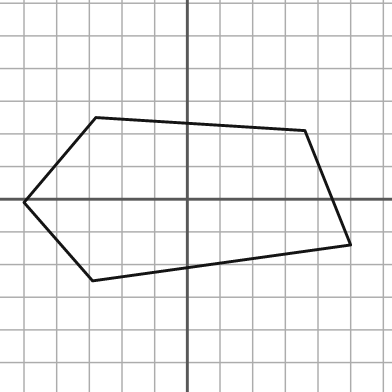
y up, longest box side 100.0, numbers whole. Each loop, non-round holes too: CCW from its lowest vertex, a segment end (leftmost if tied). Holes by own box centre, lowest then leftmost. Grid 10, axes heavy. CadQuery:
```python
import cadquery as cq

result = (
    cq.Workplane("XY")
    .moveTo(-29.0, -25.0)
    .lineTo(50.0, -14.0)
    .lineTo(36.0, 21.0)
    .lineTo(-28.0, 25.0)
    .lineTo(-50.0, -1.0)
    .close()
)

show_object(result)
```